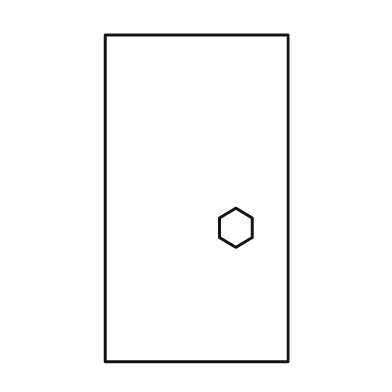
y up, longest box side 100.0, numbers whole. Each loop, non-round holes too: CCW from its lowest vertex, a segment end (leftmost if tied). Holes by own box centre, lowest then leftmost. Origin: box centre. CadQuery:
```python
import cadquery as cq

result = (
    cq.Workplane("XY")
    .moveTo(-28.0, -50.0)
    .lineTo(28.0, -50.0)
    .lineTo(28.0, 50.0)
    .lineTo(-28.0, 50.0)
    .close()
    .moveTo(12.0, -15.0)
    .lineTo(17.0, -12.0)
    .lineTo(17.0, -6.0)
    .lineTo(12.0, -3.0)
    .lineTo(7.0, -6.0)
    .lineTo(7.0, -12.0)
    .close()
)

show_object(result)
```